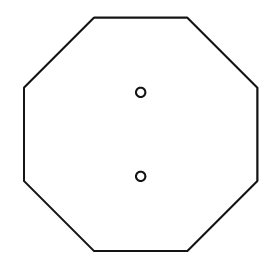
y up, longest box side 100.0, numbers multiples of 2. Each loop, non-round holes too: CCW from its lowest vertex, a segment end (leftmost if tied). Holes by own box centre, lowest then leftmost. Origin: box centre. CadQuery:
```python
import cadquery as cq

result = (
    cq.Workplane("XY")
    .moveTo(-20.0, -50.0)
    .lineTo(20.0, -50.0)
    .lineTo(50.0, -20.0)
    .lineTo(50.0, 20.0)
    .lineTo(20.0, 50.0)
    .lineTo(-20.0, 50.0)
    .lineTo(-50.0, 20.0)
    .lineTo(-50.0, -20.0)
    .close()
    .moveTo(0.0, -18.0)
    .circle(2.0)
    .moveTo(0.0, 18.0)
    .circle(2.0)
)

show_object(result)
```